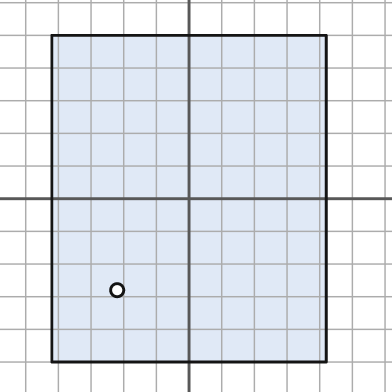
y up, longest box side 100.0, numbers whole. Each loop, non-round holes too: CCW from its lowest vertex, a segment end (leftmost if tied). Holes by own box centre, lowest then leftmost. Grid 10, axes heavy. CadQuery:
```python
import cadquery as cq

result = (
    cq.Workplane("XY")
    .moveTo(-42.0, -50.0)
    .lineTo(42.0, -50.0)
    .lineTo(42.0, 50.0)
    .lineTo(-42.0, 50.0)
    .close()
    .moveTo(-22.0, -28.0)
    .circle(2.0)
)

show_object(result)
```